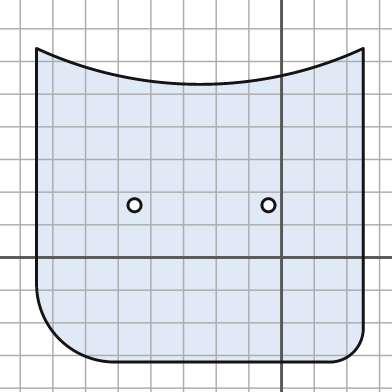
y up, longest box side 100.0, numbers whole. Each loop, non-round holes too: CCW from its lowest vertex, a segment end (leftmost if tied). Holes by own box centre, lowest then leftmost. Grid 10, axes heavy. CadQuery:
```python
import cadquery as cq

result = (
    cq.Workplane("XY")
    .moveTo(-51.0, -32.0)
    .lineTo(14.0, -32.0)
    .threePointArc((22.0, -29.0), (25.0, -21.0))
    .lineTo(25.0, 64.0)
    .threePointArc((-25.0, 53.0), (-75.0, 64.0))
    .lineTo(-75.0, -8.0)
    .threePointArc((-68.0, -25.0), (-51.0, -32.0))
    .close()
    .moveTo(-45.0, 16.0)
    .circle(2.0)
    .moveTo(-4.0, 16.0)
    .circle(2.0)
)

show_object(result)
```